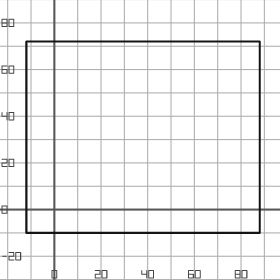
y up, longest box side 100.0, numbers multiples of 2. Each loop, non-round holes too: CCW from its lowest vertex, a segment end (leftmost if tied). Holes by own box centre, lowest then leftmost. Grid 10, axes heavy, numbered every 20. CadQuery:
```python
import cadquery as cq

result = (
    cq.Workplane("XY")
    .moveTo(-12.0, -10.0)
    .lineTo(88.0, -10.0)
    .lineTo(88.0, 72.0)
    .lineTo(-12.0, 72.0)
    .close()
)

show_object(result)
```